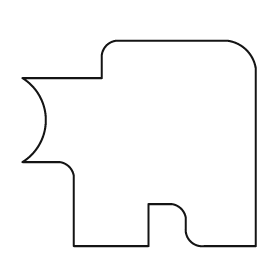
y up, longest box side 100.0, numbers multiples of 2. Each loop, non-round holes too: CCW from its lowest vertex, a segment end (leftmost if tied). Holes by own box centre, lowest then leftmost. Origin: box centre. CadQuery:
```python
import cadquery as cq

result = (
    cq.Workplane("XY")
    .moveTo(-28.0, -44.0)
    .lineTo(4.0, -44.0)
    .lineTo(4.0, -26.0)
    .lineTo(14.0, -26.0)
    .threePointArc((18.0, -28.0), (20.0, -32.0))
    .lineTo(20.0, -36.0)
    .threePointArc((22.0, -42.0), (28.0, -44.0))
    .lineTo(50.0, -44.0)
    .lineTo(50.0, 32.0)
    .threePointArc((46.0, 40.0), (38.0, 44.0))
    .lineTo(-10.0, 44.0)
    .threePointArc((-14.0, 42.0), (-16.0, 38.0))
    .lineTo(-16.0, 28.0)
    .lineTo(-50.0, 28.0)
    .threePointArc((-40.0, 10.0), (-50.0, -8.0))
    .lineTo(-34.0, -8.0)
    .threePointArc((-30.0, -10.0), (-28.0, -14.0))
    .close()
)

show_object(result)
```